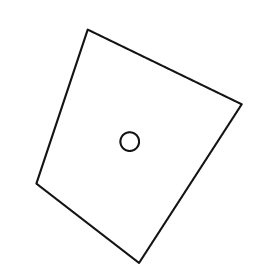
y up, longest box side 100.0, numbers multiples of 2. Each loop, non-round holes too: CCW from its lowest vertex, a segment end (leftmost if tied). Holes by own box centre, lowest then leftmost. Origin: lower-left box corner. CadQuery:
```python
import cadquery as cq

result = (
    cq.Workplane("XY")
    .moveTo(44.0, 0.0)
    .lineTo(88.0, 68.0)
    .lineTo(22.0, 100.0)
    .lineTo(0.0, 34.0)
    .close()
    .moveTo(40.0, 52.0)
    .circle(4.0)
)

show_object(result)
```